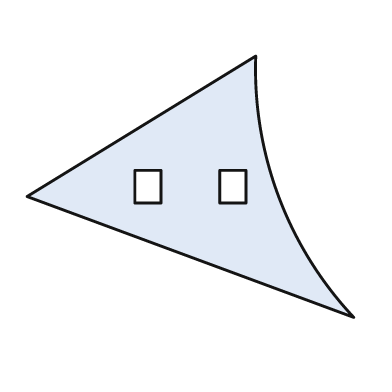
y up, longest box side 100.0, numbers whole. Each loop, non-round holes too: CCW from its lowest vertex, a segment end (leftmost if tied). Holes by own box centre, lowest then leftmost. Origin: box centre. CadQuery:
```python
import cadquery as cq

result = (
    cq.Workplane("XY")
    .moveTo(50.0, -40.0)
    .threePointArc((27.0, -3.0), (20.0, 40.0))
    .lineTo(-50.0, -3.0)
    .close()
    .moveTo(-17.0, -5.0)
    .lineTo(-9.0, -5.0)
    .lineTo(-9.0, 5.0)
    .lineTo(-17.0, 5.0)
    .close()
    .moveTo(9.0, -5.0)
    .lineTo(17.0, -5.0)
    .lineTo(17.0, 5.0)
    .lineTo(9.0, 5.0)
    .close()
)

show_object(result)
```